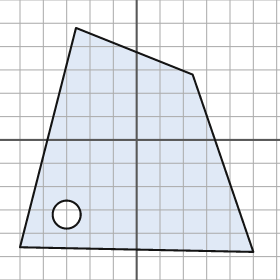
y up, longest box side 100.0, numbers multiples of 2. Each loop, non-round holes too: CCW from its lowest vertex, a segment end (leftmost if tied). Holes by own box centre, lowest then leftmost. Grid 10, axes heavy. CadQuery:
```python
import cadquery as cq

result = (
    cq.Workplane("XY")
    .moveTo(50.0, -48.0)
    .lineTo(24.0, 28.0)
    .lineTo(-26.0, 48.0)
    .lineTo(-50.0, -46.0)
    .close()
    .moveTo(-30.0, -32.0)
    .circle(6.0)
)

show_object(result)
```